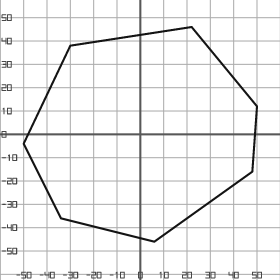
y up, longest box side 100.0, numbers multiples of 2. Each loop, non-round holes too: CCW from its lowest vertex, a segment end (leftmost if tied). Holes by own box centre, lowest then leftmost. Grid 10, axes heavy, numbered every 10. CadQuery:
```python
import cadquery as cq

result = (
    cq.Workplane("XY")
    .moveTo(6.0, -46.0)
    .lineTo(48.0, -16.0)
    .lineTo(50.0, 12.0)
    .lineTo(22.0, 46.0)
    .lineTo(-30.0, 38.0)
    .lineTo(-50.0, -4.0)
    .lineTo(-34.0, -36.0)
    .close()
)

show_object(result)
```